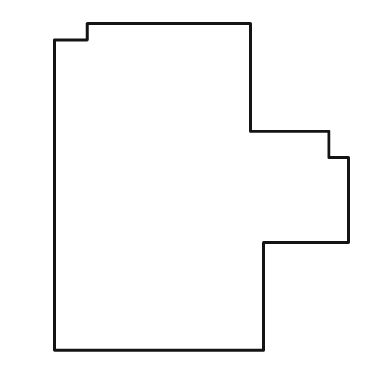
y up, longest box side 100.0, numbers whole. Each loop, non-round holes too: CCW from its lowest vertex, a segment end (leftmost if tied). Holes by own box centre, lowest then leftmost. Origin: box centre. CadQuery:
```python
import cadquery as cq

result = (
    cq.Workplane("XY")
    .moveTo(-45.0, -50.0)
    .lineTo(19.0, -50.0)
    .lineTo(19.0, -17.0)
    .lineTo(45.0, -17.0)
    .lineTo(45.0, 9.0)
    .lineTo(39.0, 9.0)
    .lineTo(39.0, 17.0)
    .lineTo(15.0, 17.0)
    .lineTo(15.0, 50.0)
    .lineTo(-35.0, 50.0)
    .lineTo(-35.0, 45.0)
    .lineTo(-45.0, 45.0)
    .close()
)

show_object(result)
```